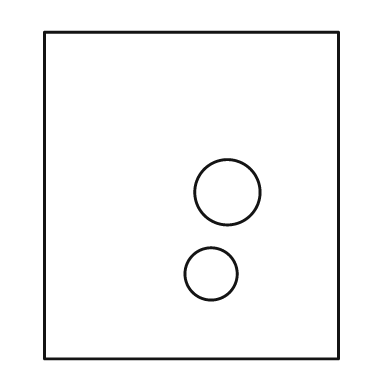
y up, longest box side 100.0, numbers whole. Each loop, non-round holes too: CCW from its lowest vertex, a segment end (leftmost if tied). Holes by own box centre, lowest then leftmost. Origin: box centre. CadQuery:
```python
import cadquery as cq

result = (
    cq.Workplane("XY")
    .moveTo(-45.0, -50.0)
    .lineTo(45.0, -50.0)
    .lineTo(45.0, 50.0)
    .lineTo(-45.0, 50.0)
    .close()
    .moveTo(6.0, -24.0)
    .circle(8.0)
    .moveTo(11.0, 1.0)
    .circle(10.0)
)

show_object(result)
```